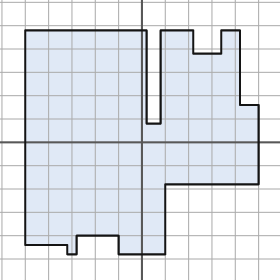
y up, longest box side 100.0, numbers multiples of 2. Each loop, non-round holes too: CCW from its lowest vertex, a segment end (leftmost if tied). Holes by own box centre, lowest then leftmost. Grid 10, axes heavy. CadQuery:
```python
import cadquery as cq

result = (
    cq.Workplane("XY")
    .moveTo(-32.0, -48.0)
    .lineTo(-28.0, -48.0)
    .lineTo(-28.0, -40.0)
    .lineTo(-10.0, -40.0)
    .lineTo(-10.0, -48.0)
    .lineTo(10.0, -48.0)
    .lineTo(10.0, -18.0)
    .lineTo(50.0, -18.0)
    .lineTo(50.0, 16.0)
    .lineTo(42.0, 16.0)
    .lineTo(42.0, 48.0)
    .lineTo(34.0, 48.0)
    .lineTo(34.0, 38.0)
    .lineTo(22.0, 38.0)
    .lineTo(22.0, 48.0)
    .lineTo(8.0, 48.0)
    .lineTo(8.0, 8.0)
    .lineTo(2.0, 8.0)
    .lineTo(2.0, 48.0)
    .lineTo(-50.0, 48.0)
    .lineTo(-50.0, -44.0)
    .lineTo(-32.0, -44.0)
    .close()
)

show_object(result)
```